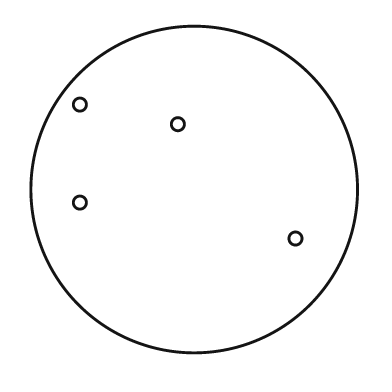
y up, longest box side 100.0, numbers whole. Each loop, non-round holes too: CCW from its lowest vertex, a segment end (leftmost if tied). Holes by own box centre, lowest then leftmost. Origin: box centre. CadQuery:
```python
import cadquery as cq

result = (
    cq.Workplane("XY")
    .moveTo(0.0, 0.0)
    .circle(50.0)
    .moveTo(31.0, -15.0)
    .circle(2.0)
    .moveTo(-35.0, -4.0)
    .circle(2.0)
    .moveTo(-5.0, 20.0)
    .circle(2.0)
    .moveTo(-35.0, 26.0)
    .circle(2.0)
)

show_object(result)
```